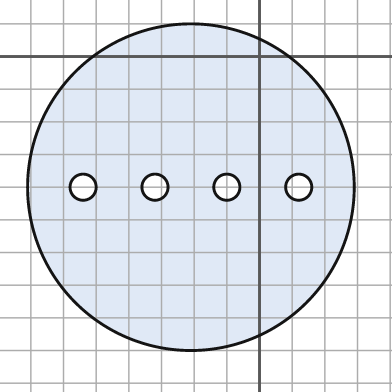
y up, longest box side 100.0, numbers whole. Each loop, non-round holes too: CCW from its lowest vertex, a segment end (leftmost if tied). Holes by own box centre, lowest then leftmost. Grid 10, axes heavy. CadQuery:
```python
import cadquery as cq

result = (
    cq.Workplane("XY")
    .moveTo(-21.0, -40.0)
    .circle(50.0)
    .moveTo(-54.0, -40.0)
    .circle(4.0)
    .moveTo(-32.0, -40.0)
    .circle(4.0)
    .moveTo(-10.0, -40.0)
    .circle(4.0)
    .moveTo(12.0, -40.0)
    .circle(4.0)
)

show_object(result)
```